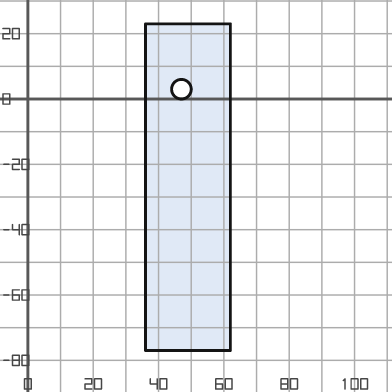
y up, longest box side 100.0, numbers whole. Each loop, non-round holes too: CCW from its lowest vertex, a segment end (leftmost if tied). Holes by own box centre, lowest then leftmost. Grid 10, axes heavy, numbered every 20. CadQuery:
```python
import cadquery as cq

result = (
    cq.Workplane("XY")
    .moveTo(36.0, -77.0)
    .lineTo(62.0, -77.0)
    .lineTo(62.0, 23.0)
    .lineTo(36.0, 23.0)
    .close()
    .moveTo(47.0, 3.0)
    .circle(3.0)
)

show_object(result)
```